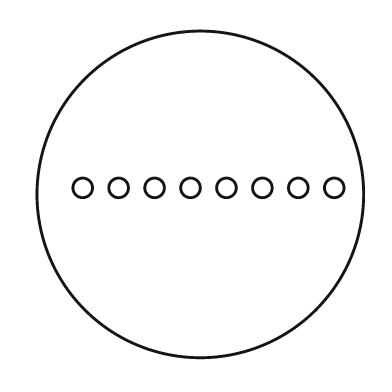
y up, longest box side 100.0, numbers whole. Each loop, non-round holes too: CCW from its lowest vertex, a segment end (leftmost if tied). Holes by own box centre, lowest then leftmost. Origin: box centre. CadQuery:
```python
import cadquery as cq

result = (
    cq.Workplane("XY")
    .moveTo(0.0, 0.0)
    .circle(50.0)
    .moveTo(-36.0, 2.0)
    .circle(3.0)
    .moveTo(-25.0, 2.0)
    .circle(3.0)
    .moveTo(-14.0, 2.0)
    .circle(3.0)
    .moveTo(-3.0, 2.0)
    .circle(3.0)
    .moveTo(8.0, 2.0)
    .circle(3.0)
    .moveTo(19.0, 2.0)
    .circle(3.0)
    .moveTo(30.0, 2.0)
    .circle(3.0)
    .moveTo(41.0, 2.0)
    .circle(3.0)
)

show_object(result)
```